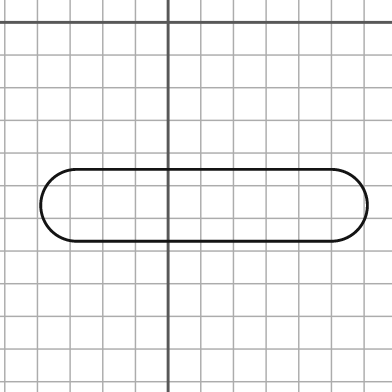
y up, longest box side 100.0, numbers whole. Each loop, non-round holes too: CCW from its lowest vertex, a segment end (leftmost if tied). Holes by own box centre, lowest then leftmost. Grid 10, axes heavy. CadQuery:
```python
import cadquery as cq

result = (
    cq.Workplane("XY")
    .moveTo(-28.0, -67.0)
    .lineTo(50.0, -67.0)
    .threePointArc((61.0, -56.0), (50.0, -45.0))
    .lineTo(-28.0, -45.0)
    .threePointArc((-39.0, -56.0), (-28.0, -67.0))
    .close()
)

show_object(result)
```